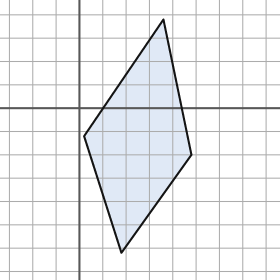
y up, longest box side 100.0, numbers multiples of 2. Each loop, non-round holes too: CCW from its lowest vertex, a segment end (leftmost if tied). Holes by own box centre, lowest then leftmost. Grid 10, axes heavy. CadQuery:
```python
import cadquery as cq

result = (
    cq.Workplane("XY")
    .moveTo(18.0, -62.0)
    .lineTo(48.0, -20.0)
    .lineTo(36.0, 38.0)
    .lineTo(2.0, -12.0)
    .close()
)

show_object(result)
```